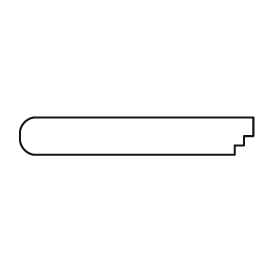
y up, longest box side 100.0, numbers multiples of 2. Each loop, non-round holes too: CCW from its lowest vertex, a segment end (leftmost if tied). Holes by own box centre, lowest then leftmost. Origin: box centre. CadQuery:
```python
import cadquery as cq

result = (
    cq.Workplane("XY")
    .moveTo(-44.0, -8.0)
    .lineTo(42.0, -8.0)
    .lineTo(42.0, -4.0)
    .lineTo(46.0, -4.0)
    .lineTo(46.0, 0.0)
    .lineTo(50.0, 0.0)
    .lineTo(50.0, 8.0)
    .lineTo(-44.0, 8.0)
    .threePointArc((-48.0, 6.0), (-50.0, 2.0))
    .lineTo(-50.0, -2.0)
    .threePointArc((-48.0, -6.0), (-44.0, -8.0))
    .close()
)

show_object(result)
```